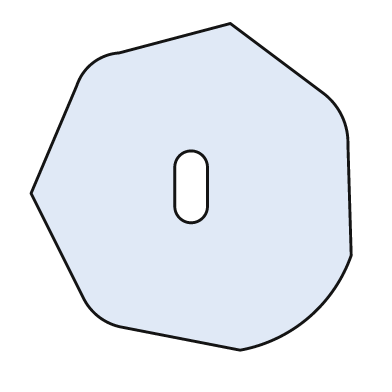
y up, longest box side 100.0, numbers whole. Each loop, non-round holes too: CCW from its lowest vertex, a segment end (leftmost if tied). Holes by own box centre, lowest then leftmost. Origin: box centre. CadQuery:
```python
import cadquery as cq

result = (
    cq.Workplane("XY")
    .moveTo(15.0, -50.0)
    .threePointArc((36.0, -40.0), (49.0, -21.0))
    .lineTo(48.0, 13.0)
    .threePointArc((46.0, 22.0), (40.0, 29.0))
    .lineTo(12.0, 50.0)
    .lineTo(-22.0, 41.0)
    .threePointArc((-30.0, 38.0), (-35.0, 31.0))
    .lineTo(-49.0, -2.0)
    .lineTo(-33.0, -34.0)
    .threePointArc((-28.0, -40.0), (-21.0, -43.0))
    .close()
    .moveTo(-5.0, -6.0)
    .threePointArc((0.0, -11.0), (5.0, -6.0))
    .lineTo(5.0, 6.0)
    .threePointArc((0.0, 11.0), (-5.0, 6.0))
    .close()
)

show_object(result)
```